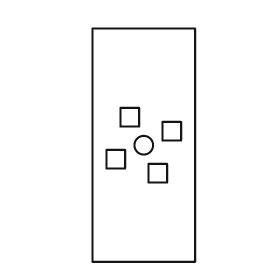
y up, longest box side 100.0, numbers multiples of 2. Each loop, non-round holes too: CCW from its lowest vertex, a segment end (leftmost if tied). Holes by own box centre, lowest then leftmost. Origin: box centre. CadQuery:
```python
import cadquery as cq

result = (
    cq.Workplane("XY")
    .moveTo(-22.0, -50.0)
    .lineTo(22.0, -50.0)
    .lineTo(22.0, 50.0)
    .lineTo(-22.0, 50.0)
    .close()
    .moveTo(2.0, -16.0)
    .lineTo(10.0, -16.0)
    .lineTo(10.0, -8.0)
    .lineTo(2.0, -8.0)
    .close()
    .moveTo(-16.0, -10.0)
    .lineTo(-8.0, -10.0)
    .lineTo(-8.0, -2.0)
    .lineTo(-16.0, -2.0)
    .close()
    .moveTo(0.0, 0.0)
    .circle(4.0)
    .moveTo(8.0, 2.0)
    .lineTo(16.0, 2.0)
    .lineTo(16.0, 10.0)
    .lineTo(8.0, 10.0)
    .close()
    .moveTo(-10.0, 8.0)
    .lineTo(-2.0, 8.0)
    .lineTo(-2.0, 16.0)
    .lineTo(-10.0, 16.0)
    .close()
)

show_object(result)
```